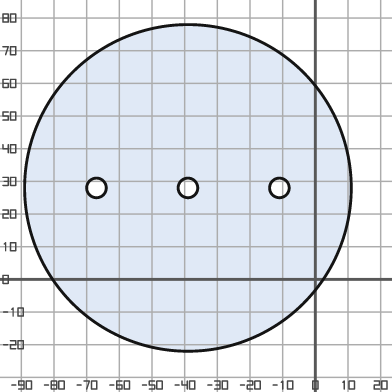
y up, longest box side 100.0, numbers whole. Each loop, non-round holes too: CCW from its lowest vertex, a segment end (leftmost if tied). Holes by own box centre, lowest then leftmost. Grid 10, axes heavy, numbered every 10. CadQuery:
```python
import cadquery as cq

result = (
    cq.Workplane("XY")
    .moveTo(-39.0, 28.0)
    .circle(50.0)
    .moveTo(-67.0, 28.0)
    .circle(3.0)
    .moveTo(-39.0, 28.0)
    .circle(3.0)
    .moveTo(-11.0, 28.0)
    .circle(3.0)
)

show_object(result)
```